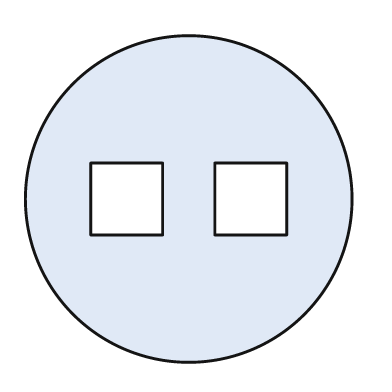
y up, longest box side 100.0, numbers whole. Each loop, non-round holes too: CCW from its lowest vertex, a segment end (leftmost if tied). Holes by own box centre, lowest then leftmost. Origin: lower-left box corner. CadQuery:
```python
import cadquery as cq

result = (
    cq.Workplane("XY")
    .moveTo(50.0, 50.0)
    .circle(50.0)
    .moveTo(20.0, 39.0)
    .lineTo(42.0, 39.0)
    .lineTo(42.0, 61.0)
    .lineTo(20.0, 61.0)
    .close()
    .moveTo(58.0, 39.0)
    .lineTo(80.0, 39.0)
    .lineTo(80.0, 61.0)
    .lineTo(58.0, 61.0)
    .close()
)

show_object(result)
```